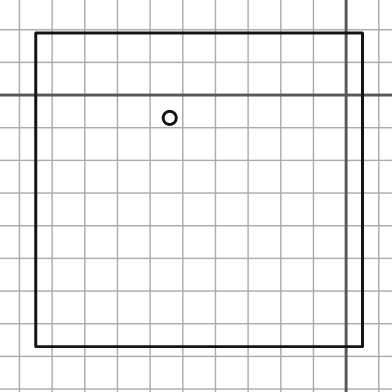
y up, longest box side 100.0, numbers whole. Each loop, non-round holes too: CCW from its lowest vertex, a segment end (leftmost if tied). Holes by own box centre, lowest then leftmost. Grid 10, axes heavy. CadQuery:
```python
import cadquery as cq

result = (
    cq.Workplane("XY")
    .moveTo(-95.0, -77.0)
    .lineTo(5.0, -77.0)
    .lineTo(5.0, 19.0)
    .lineTo(-95.0, 19.0)
    .close()
    .moveTo(-54.0, -7.0)
    .circle(2.0)
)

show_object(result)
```